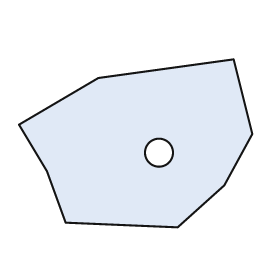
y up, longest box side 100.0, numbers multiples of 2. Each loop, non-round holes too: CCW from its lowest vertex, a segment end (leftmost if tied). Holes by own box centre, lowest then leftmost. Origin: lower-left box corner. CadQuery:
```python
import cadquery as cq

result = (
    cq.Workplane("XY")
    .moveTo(68.0, 0.0)
    .lineTo(88.0, 18.0)
    .lineTo(100.0, 40.0)
    .lineTo(92.0, 72.0)
    .lineTo(34.0, 64.0)
    .lineTo(0.0, 44.0)
    .lineTo(12.0, 24.0)
    .lineTo(20.0, 2.0)
    .close()
    .moveTo(60.0, 32.0)
    .circle(6.0)
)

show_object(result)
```